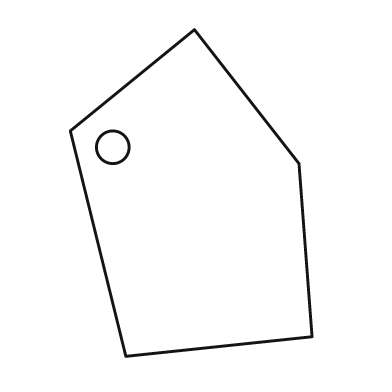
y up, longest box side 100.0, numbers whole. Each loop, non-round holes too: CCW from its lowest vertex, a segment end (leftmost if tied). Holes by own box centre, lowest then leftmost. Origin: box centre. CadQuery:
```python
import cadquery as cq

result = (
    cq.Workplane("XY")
    .moveTo(-20.0, -50.0)
    .lineTo(37.0, -44.0)
    .lineTo(33.0, 9.0)
    .lineTo(1.0, 50.0)
    .lineTo(-37.0, 19.0)
    .close()
    .moveTo(-24.0, 14.0)
    .circle(5.0)
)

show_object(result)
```